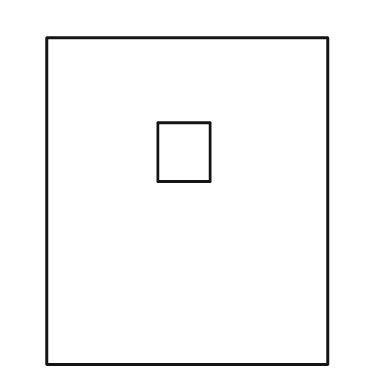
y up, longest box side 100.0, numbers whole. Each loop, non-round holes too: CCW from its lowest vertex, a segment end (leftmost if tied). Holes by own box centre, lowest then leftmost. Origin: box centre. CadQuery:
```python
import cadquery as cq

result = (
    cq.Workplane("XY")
    .moveTo(-43.0, -50.0)
    .lineTo(43.0, -50.0)
    .lineTo(43.0, 50.0)
    .lineTo(-43.0, 50.0)
    .close()
    .moveTo(-9.0, 6.0)
    .lineTo(7.0, 6.0)
    .lineTo(7.0, 24.0)
    .lineTo(-9.0, 24.0)
    .close()
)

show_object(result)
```